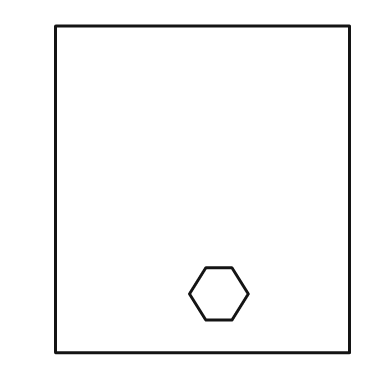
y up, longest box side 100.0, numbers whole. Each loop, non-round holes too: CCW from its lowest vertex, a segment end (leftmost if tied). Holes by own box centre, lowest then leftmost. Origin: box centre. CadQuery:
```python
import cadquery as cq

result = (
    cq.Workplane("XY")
    .moveTo(-45.0, -50.0)
    .lineTo(45.0, -50.0)
    .lineTo(45.0, 50.0)
    .lineTo(-45.0, 50.0)
    .close()
    .moveTo(1.0, -40.0)
    .lineTo(9.0, -40.0)
    .lineTo(14.0, -32.0)
    .lineTo(9.0, -24.0)
    .lineTo(1.0, -24.0)
    .lineTo(-4.0, -32.0)
    .close()
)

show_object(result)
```